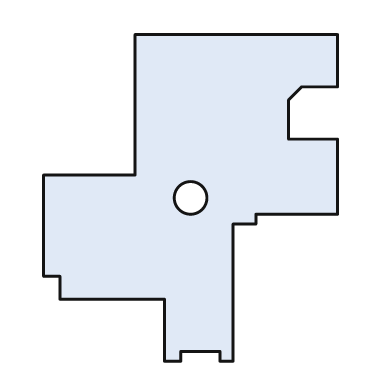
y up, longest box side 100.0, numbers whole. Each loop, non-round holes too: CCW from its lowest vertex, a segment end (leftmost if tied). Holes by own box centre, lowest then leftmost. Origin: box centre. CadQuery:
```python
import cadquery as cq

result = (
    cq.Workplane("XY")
    .moveTo(-8.0, -50.0)
    .lineTo(-3.0, -50.0)
    .lineTo(-3.0, -47.0)
    .lineTo(9.0, -47.0)
    .lineTo(9.0, -50.0)
    .lineTo(13.0, -50.0)
    .lineTo(13.0, -8.0)
    .lineTo(20.0, -8.0)
    .lineTo(20.0, -5.0)
    .lineTo(45.0, -5.0)
    .lineTo(45.0, 18.0)
    .lineTo(30.0, 18.0)
    .lineTo(30.0, 30.0)
    .lineTo(34.0, 34.0)
    .lineTo(45.0, 34.0)
    .lineTo(45.0, 50.0)
    .lineTo(-17.0, 50.0)
    .lineTo(-17.0, 7.0)
    .lineTo(-45.0, 7.0)
    .lineTo(-45.0, -24.0)
    .lineTo(-40.0, -24.0)
    .lineTo(-40.0, -31.0)
    .lineTo(-8.0, -31.0)
    .close()
    .moveTo(0.0, 0.0)
    .circle(5.0)
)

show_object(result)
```